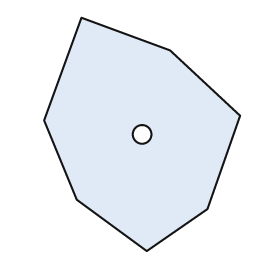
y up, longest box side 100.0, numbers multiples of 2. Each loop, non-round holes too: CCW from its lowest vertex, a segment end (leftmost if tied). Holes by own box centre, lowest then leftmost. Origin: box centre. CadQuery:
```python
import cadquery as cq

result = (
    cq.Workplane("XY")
    .moveTo(2.0, -50.0)
    .lineTo(28.0, -32.0)
    .lineTo(42.0, 8.0)
    .lineTo(12.0, 36.0)
    .lineTo(-26.0, 50.0)
    .lineTo(-42.0, 6.0)
    .lineTo(-28.0, -28.0)
    .close()
    .moveTo(0.0, 0.0)
    .circle(4.0)
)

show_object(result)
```